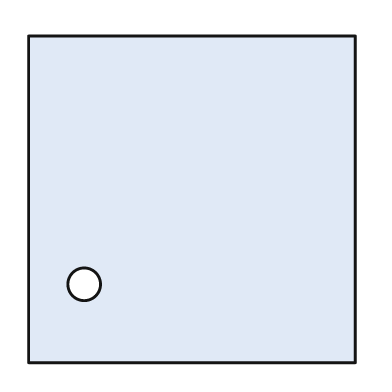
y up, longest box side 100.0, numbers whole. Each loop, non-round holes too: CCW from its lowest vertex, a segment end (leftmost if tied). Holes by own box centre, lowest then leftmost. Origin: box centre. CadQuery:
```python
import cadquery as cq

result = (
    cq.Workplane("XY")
    .moveTo(-50.0, -50.0)
    .lineTo(50.0, -50.0)
    .lineTo(50.0, 50.0)
    .lineTo(-50.0, 50.0)
    .close()
    .moveTo(-33.0, -26.0)
    .circle(5.0)
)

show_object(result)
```